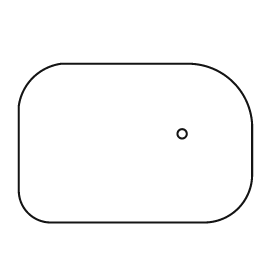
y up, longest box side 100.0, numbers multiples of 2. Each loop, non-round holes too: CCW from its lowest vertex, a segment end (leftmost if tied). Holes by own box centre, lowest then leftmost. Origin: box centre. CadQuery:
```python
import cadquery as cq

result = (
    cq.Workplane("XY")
    .moveTo(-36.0, -34.0)
    .lineTo(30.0, -34.0)
    .threePointArc((44.0, -28.0), (50.0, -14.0))
    .lineTo(50.0, 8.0)
    .threePointArc((42.0, 26.0), (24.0, 34.0))
    .lineTo(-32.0, 34.0)
    .threePointArc((-44.0, 28.0), (-50.0, 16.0))
    .lineTo(-50.0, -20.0)
    .threePointArc((-46.0, -30.0), (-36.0, -34.0))
    .close()
    .moveTo(20.0, 4.0)
    .circle(2.0)
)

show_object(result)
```